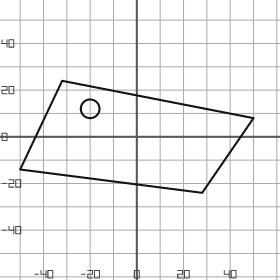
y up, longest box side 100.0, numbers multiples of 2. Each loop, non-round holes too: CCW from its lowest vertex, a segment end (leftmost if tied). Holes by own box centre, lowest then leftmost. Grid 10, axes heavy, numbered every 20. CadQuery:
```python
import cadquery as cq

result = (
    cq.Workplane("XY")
    .moveTo(28.0, -24.0)
    .lineTo(50.0, 8.0)
    .lineTo(-32.0, 24.0)
    .lineTo(-50.0, -14.0)
    .close()
    .moveTo(-20.0, 12.0)
    .circle(4.0)
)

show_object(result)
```